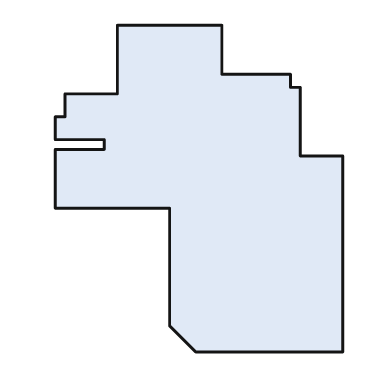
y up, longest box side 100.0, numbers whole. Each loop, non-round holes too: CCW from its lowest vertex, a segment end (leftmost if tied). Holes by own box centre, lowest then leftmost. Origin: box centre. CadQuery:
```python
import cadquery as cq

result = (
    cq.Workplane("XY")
    .moveTo(-1.0, -50.0)
    .lineTo(44.0, -50.0)
    .lineTo(44.0, 10.0)
    .lineTo(31.0, 10.0)
    .lineTo(31.0, 31.0)
    .lineTo(28.0, 31.0)
    .lineTo(28.0, 35.0)
    .lineTo(7.0, 35.0)
    .lineTo(7.0, 50.0)
    .lineTo(-25.0, 50.0)
    .lineTo(-25.0, 29.0)
    .lineTo(-41.0, 29.0)
    .lineTo(-41.0, 22.0)
    .lineTo(-44.0, 22.0)
    .lineTo(-44.0, 15.0)
    .lineTo(-29.0, 15.0)
    .lineTo(-29.0, 12.0)
    .lineTo(-44.0, 12.0)
    .lineTo(-44.0, -6.0)
    .lineTo(-9.0, -6.0)
    .lineTo(-9.0, -42.0)
    .close()
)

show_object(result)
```